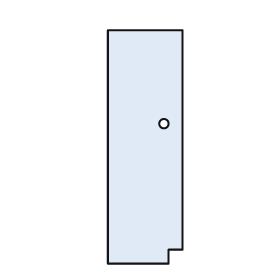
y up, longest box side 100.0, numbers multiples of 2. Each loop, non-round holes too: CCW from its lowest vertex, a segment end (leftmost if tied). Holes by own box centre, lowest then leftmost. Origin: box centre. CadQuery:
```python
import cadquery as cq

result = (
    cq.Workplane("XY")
    .moveTo(-16.0, -50.0)
    .lineTo(10.0, -50.0)
    .lineTo(10.0, -44.0)
    .lineTo(16.0, -44.0)
    .lineTo(16.0, 50.0)
    .lineTo(-16.0, 50.0)
    .close()
    .moveTo(8.0, 10.0)
    .circle(2.0)
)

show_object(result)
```